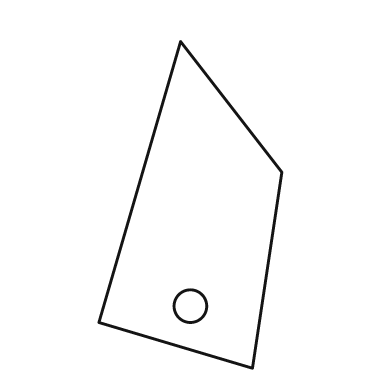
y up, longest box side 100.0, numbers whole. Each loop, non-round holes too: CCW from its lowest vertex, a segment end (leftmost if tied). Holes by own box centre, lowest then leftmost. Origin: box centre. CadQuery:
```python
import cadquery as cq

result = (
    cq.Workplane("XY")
    .moveTo(19.0, -50.0)
    .lineTo(28.0, 10.0)
    .lineTo(-3.0, 50.0)
    .lineTo(-28.0, -36.0)
    .close()
    .moveTo(0.0, -31.0)
    .circle(5.0)
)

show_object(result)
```